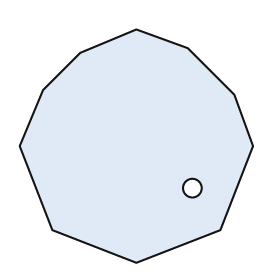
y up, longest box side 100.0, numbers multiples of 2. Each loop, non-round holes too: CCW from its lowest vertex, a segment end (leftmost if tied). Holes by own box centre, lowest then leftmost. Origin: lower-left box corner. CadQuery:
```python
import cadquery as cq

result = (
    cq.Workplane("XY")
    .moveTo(50.0, 0.0)
    .lineTo(86.0, 14.0)
    .lineTo(100.0, 50.0)
    .lineTo(92.0, 72.0)
    .lineTo(72.0, 92.0)
    .lineTo(50.0, 100.0)
    .lineTo(26.0, 90.0)
    .lineTo(10.0, 74.0)
    .lineTo(0.0, 50.0)
    .lineTo(14.0, 14.0)
    .close()
    .moveTo(74.0, 32.0)
    .circle(4.0)
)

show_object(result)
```